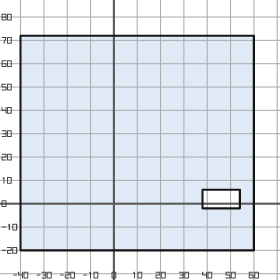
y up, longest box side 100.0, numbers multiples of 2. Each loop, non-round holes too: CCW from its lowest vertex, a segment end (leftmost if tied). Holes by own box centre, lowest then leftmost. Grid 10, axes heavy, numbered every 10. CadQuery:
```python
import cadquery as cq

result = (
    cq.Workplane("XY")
    .moveTo(-40.0, -20.0)
    .lineTo(60.0, -20.0)
    .lineTo(60.0, 72.0)
    .lineTo(-40.0, 72.0)
    .close()
    .moveTo(38.0, -2.0)
    .lineTo(54.0, -2.0)
    .lineTo(54.0, 6.0)
    .lineTo(38.0, 6.0)
    .close()
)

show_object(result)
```